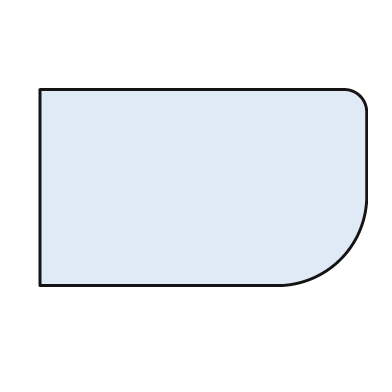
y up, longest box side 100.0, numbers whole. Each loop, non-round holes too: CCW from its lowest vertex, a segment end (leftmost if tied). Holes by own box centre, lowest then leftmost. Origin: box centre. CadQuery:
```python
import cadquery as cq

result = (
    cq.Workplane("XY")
    .moveTo(-50.0, -30.0)
    .lineTo(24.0, -30.0)
    .threePointArc((42.0, -22.0), (50.0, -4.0))
    .lineTo(50.0, 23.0)
    .threePointArc((48.0, 28.0), (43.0, 30.0))
    .lineTo(-50.0, 30.0)
    .close()
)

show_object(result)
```